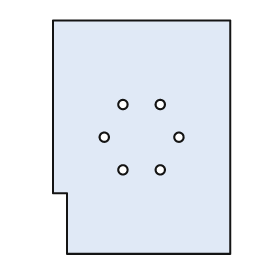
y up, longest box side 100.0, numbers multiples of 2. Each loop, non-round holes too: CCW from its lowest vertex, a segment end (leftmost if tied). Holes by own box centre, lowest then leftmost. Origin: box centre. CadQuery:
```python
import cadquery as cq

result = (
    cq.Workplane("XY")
    .moveTo(-32.0, -50.0)
    .lineTo(38.0, -50.0)
    .lineTo(38.0, 50.0)
    .lineTo(-38.0, 50.0)
    .lineTo(-38.0, -24.0)
    .lineTo(-32.0, -24.0)
    .close()
    .moveTo(-8.0, -14.0)
    .circle(2.0)
    .moveTo(8.0, -14.0)
    .circle(2.0)
    .moveTo(-16.0, 0.0)
    .circle(2.0)
    .moveTo(16.0, 0.0)
    .circle(2.0)
    .moveTo(-8.0, 14.0)
    .circle(2.0)
    .moveTo(8.0, 14.0)
    .circle(2.0)
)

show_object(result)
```